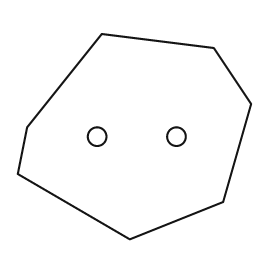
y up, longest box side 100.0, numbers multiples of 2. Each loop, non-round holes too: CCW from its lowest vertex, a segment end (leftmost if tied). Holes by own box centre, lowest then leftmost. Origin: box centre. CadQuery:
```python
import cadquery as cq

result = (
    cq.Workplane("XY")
    .moveTo(-2.0, -44.0)
    .lineTo(38.0, -28.0)
    .lineTo(50.0, 14.0)
    .lineTo(34.0, 38.0)
    .lineTo(-14.0, 44.0)
    .lineTo(-46.0, 4.0)
    .lineTo(-50.0, -16.0)
    .close()
    .moveTo(-16.0, 0.0)
    .circle(4.0)
    .moveTo(18.0, 0.0)
    .circle(4.0)
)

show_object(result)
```